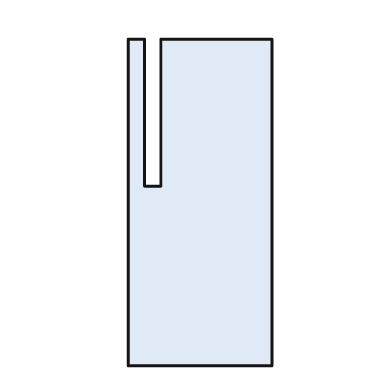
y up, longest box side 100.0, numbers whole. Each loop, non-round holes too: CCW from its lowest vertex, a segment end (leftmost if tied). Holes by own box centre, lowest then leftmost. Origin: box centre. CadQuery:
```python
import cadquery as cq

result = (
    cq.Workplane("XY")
    .moveTo(-22.0, -50.0)
    .lineTo(22.0, -50.0)
    .lineTo(22.0, 50.0)
    .lineTo(-12.0, 50.0)
    .lineTo(-12.0, 5.0)
    .lineTo(-17.0, 5.0)
    .lineTo(-17.0, 50.0)
    .lineTo(-22.0, 50.0)
    .close()
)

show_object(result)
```